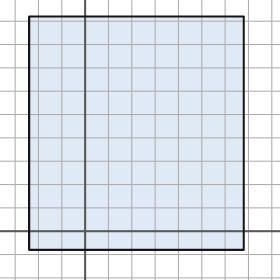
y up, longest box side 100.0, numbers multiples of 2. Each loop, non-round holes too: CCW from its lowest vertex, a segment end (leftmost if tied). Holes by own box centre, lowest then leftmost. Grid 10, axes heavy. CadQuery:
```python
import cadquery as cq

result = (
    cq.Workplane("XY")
    .moveTo(-24.0, -8.0)
    .lineTo(68.0, -8.0)
    .lineTo(68.0, 92.0)
    .lineTo(-24.0, 92.0)
    .close()
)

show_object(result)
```